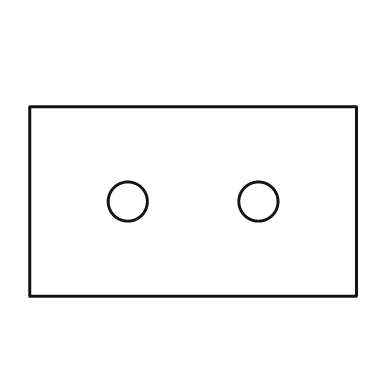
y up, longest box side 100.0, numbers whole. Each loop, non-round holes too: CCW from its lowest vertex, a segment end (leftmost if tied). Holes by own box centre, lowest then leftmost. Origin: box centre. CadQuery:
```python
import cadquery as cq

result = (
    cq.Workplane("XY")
    .moveTo(-50.0, -29.0)
    .lineTo(50.0, -29.0)
    .lineTo(50.0, 29.0)
    .lineTo(-50.0, 29.0)
    .close()
    .moveTo(-20.0, 0.0)
    .circle(6.0)
    .moveTo(20.0, 0.0)
    .circle(6.0)
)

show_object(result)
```